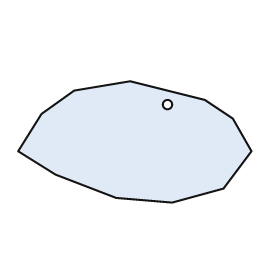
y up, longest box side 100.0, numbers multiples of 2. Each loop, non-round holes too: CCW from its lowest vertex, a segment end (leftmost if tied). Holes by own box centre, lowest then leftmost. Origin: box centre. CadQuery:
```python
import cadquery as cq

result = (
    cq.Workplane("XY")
    .moveTo(16.0, -26.0)
    .lineTo(38.0, -20.0)
    .lineTo(50.0, -4.0)
    .lineTo(42.0, 10.0)
    .lineTo(30.0, 18.0)
    .lineTo(-2.0, 26.0)
    .lineTo(-26.0, 22.0)
    .lineTo(-40.0, 12.0)
    .lineTo(-50.0, -4.0)
    .lineTo(-34.0, -14.0)
    .lineTo(-8.0, -24.0)
    .close()
    .moveTo(14.0, 16.0)
    .circle(2.0)
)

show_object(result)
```